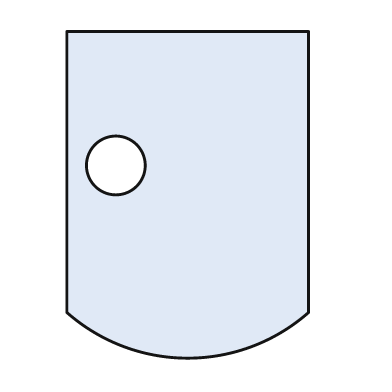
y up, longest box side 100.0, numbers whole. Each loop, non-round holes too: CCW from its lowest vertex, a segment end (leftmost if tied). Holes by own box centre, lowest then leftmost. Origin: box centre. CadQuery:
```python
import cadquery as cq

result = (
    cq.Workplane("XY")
    .moveTo(-37.0, -36.0)
    .threePointArc((0.0, -50.0), (37.0, -36.0))
    .lineTo(37.0, 50.0)
    .lineTo(-37.0, 50.0)
    .close()
    .moveTo(-22.0, 9.0)
    .circle(9.0)
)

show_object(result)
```